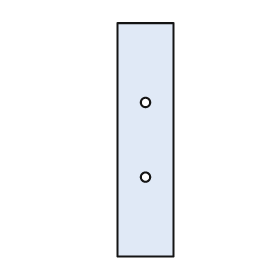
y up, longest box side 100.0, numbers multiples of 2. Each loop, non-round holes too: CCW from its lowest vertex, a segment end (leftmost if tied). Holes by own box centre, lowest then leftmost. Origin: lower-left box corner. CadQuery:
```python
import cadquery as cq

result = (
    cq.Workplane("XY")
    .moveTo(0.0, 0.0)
    .lineTo(24.0, 0.0)
    .lineTo(24.0, 100.0)
    .lineTo(0.0, 100.0)
    .close()
    .moveTo(12.0, 34.0)
    .circle(2.0)
    .moveTo(12.0, 66.0)
    .circle(2.0)
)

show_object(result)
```